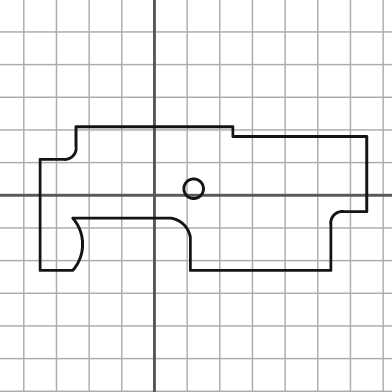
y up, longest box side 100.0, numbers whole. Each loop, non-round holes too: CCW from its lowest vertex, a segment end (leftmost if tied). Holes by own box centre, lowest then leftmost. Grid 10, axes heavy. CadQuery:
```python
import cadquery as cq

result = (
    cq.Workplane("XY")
    .moveTo(-35.0, -23.0)
    .lineTo(-25.0, -23.0)
    .threePointArc((-22.0, -15.0), (-25.0, -7.0))
    .lineTo(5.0, -7.0)
    .threePointArc((9.0, -9.0), (11.0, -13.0))
    .lineTo(11.0, -23.0)
    .lineTo(54.0, -23.0)
    .lineTo(54.0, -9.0)
    .threePointArc((55.0, -6.0), (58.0, -5.0))
    .lineTo(65.0, -5.0)
    .lineTo(65.0, 18.0)
    .lineTo(24.0, 18.0)
    .lineTo(24.0, 21.0)
    .lineTo(-24.0, 21.0)
    .lineTo(-24.0, 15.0)
    .threePointArc((-25.0, 12.0), (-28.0, 11.0))
    .lineTo(-35.0, 11.0)
    .close()
    .moveTo(12.0, 2.0)
    .circle(3.0)
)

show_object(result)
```